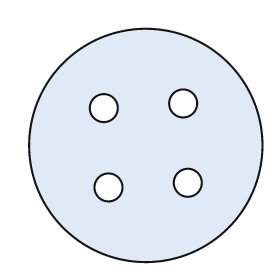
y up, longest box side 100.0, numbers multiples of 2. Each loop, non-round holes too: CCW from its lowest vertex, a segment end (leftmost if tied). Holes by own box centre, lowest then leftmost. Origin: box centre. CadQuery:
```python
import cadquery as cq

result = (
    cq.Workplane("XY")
    .moveTo(0.0, 0.0)
    .circle(50.0)
    .moveTo(-16.0, -18.0)
    .circle(6.0)
    .moveTo(18.0, -16.0)
    .circle(6.0)
    .moveTo(-18.0, 16.0)
    .circle(6.0)
    .moveTo(16.0, 18.0)
    .circle(6.0)
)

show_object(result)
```